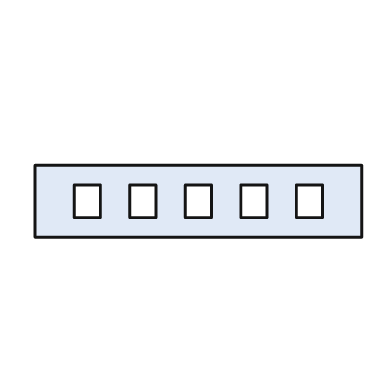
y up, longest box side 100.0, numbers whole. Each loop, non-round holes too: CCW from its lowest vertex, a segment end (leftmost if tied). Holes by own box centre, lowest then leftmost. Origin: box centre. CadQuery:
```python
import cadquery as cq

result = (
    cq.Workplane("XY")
    .moveTo(-50.0, -11.0)
    .lineTo(50.0, -11.0)
    .lineTo(50.0, 11.0)
    .lineTo(-50.0, 11.0)
    .close()
    .moveTo(-38.0, -5.0)
    .lineTo(-30.0, -5.0)
    .lineTo(-30.0, 5.0)
    .lineTo(-38.0, 5.0)
    .close()
    .moveTo(-21.0, -5.0)
    .lineTo(-13.0, -5.0)
    .lineTo(-13.0, 5.0)
    .lineTo(-21.0, 5.0)
    .close()
    .moveTo(-4.0, -5.0)
    .lineTo(4.0, -5.0)
    .lineTo(4.0, 5.0)
    .lineTo(-4.0, 5.0)
    .close()
    .moveTo(13.0, -5.0)
    .lineTo(21.0, -5.0)
    .lineTo(21.0, 5.0)
    .lineTo(13.0, 5.0)
    .close()
    .moveTo(30.0, -5.0)
    .lineTo(38.0, -5.0)
    .lineTo(38.0, 5.0)
    .lineTo(30.0, 5.0)
    .close()
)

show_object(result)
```